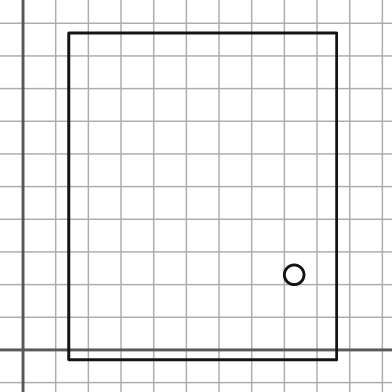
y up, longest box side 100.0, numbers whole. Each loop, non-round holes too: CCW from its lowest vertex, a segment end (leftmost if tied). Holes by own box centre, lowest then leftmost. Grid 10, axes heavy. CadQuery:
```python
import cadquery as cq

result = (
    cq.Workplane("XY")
    .moveTo(14.0, -3.0)
    .lineTo(96.0, -3.0)
    .lineTo(96.0, 97.0)
    .lineTo(14.0, 97.0)
    .close()
    .moveTo(83.0, 23.0)
    .circle(3.0)
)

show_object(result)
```